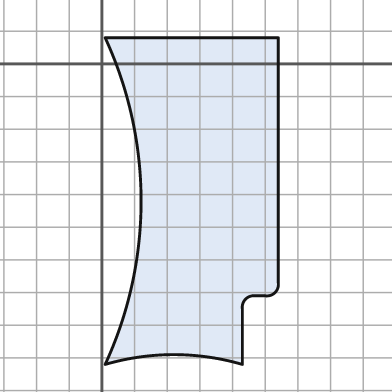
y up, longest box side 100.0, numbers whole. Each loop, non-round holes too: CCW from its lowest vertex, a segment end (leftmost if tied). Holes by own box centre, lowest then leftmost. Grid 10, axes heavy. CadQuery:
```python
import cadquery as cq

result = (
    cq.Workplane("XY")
    .moveTo(1.0, -92.0)
    .threePointArc((22.0, -89.0), (43.0, -92.0))
    .lineTo(43.0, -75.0)
    .threePointArc((44.0, -72.0), (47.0, -71.0))
    .lineTo(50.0, -71.0)
    .threePointArc((53.0, -70.0), (54.0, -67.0))
    .lineTo(54.0, 8.0)
    .lineTo(1.0, 8.0)
    .threePointArc((12.0, -42.0), (1.0, -92.0))
    .close()
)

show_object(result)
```